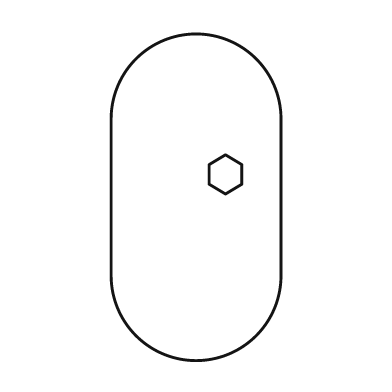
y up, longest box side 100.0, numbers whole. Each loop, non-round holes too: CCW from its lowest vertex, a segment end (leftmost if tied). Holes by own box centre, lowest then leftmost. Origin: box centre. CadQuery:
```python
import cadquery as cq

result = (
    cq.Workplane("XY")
    .moveTo(-26.0, -24.0)
    .threePointArc((0.0, -50.0), (26.0, -24.0))
    .lineTo(26.0, 24.0)
    .threePointArc((0.0, 50.0), (-26.0, 24.0))
    .close()
    .moveTo(9.0, 1.0)
    .lineTo(14.0, 4.0)
    .lineTo(14.0, 10.0)
    .lineTo(9.0, 13.0)
    .lineTo(4.0, 10.0)
    .lineTo(4.0, 4.0)
    .close()
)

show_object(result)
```